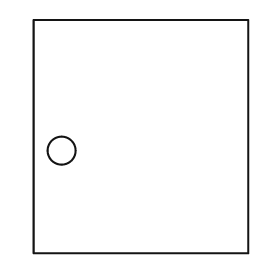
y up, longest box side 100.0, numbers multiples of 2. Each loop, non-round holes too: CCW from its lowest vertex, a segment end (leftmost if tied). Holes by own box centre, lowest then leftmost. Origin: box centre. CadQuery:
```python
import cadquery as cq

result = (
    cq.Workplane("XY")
    .moveTo(-46.0, -50.0)
    .lineTo(46.0, -50.0)
    .lineTo(46.0, 50.0)
    .lineTo(-46.0, 50.0)
    .close()
    .moveTo(-34.0, -6.0)
    .circle(6.0)
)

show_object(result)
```